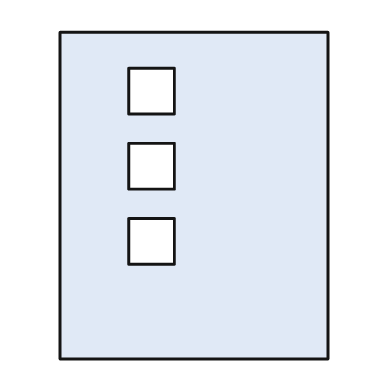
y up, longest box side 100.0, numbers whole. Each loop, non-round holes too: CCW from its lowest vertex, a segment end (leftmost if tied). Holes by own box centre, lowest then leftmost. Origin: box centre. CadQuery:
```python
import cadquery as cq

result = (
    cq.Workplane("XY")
    .moveTo(-41.0, -50.0)
    .lineTo(41.0, -50.0)
    .lineTo(41.0, 50.0)
    .lineTo(-41.0, 50.0)
    .close()
    .moveTo(-20.0, -21.0)
    .lineTo(-6.0, -21.0)
    .lineTo(-6.0, -7.0)
    .lineTo(-20.0, -7.0)
    .close()
    .moveTo(-20.0, 2.0)
    .lineTo(-6.0, 2.0)
    .lineTo(-6.0, 16.0)
    .lineTo(-20.0, 16.0)
    .close()
    .moveTo(-20.0, 25.0)
    .lineTo(-6.0, 25.0)
    .lineTo(-6.0, 39.0)
    .lineTo(-20.0, 39.0)
    .close()
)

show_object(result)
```